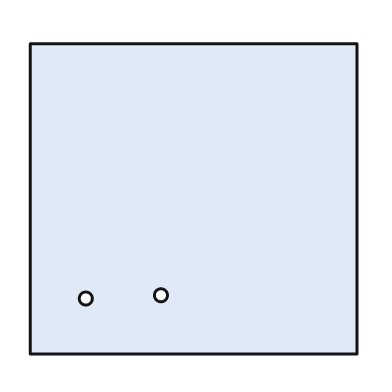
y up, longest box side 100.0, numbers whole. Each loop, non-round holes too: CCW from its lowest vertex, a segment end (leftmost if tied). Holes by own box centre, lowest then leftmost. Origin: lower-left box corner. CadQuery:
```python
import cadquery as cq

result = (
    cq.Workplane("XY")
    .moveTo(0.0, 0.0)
    .lineTo(100.0, 0.0)
    .lineTo(100.0, 95.0)
    .lineTo(0.0, 95.0)
    .close()
    .moveTo(17.0, 17.0)
    .circle(2.0)
    .moveTo(40.0, 18.0)
    .circle(2.0)
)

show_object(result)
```